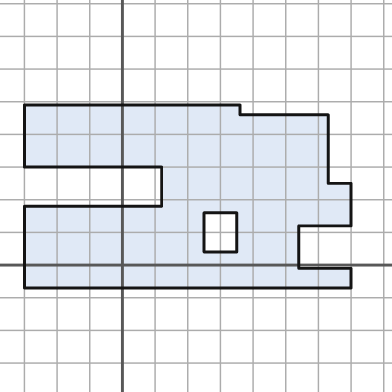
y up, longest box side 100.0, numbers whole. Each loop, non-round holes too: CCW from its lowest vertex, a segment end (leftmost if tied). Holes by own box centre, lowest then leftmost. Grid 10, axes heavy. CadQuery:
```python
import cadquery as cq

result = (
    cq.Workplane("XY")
    .moveTo(-30.0, -7.0)
    .lineTo(70.0, -7.0)
    .lineTo(70.0, -1.0)
    .lineTo(54.0, -1.0)
    .lineTo(54.0, 12.0)
    .lineTo(70.0, 12.0)
    .lineTo(70.0, 25.0)
    .lineTo(63.0, 25.0)
    .lineTo(63.0, 46.0)
    .lineTo(36.0, 46.0)
    .lineTo(36.0, 49.0)
    .lineTo(-30.0, 49.0)
    .lineTo(-30.0, 30.0)
    .lineTo(12.0, 30.0)
    .lineTo(12.0, 18.0)
    .lineTo(-30.0, 18.0)
    .close()
    .moveTo(25.0, 4.0)
    .lineTo(35.0, 4.0)
    .lineTo(35.0, 16.0)
    .lineTo(25.0, 16.0)
    .close()
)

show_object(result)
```